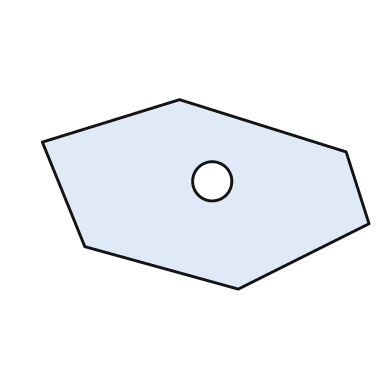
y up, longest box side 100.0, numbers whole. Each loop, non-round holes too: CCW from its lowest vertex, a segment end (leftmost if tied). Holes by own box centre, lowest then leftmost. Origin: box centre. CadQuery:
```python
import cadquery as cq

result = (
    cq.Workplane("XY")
    .moveTo(10.0, -29.0)
    .lineTo(50.0, -9.0)
    .lineTo(43.0, 13.0)
    .lineTo(-8.0, 29.0)
    .lineTo(-50.0, 16.0)
    .lineTo(-37.0, -16.0)
    .close()
    .moveTo(2.0, 4.0)
    .circle(6.0)
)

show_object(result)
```